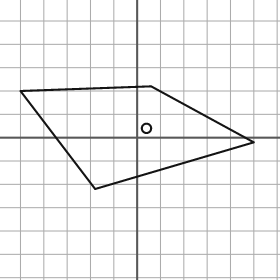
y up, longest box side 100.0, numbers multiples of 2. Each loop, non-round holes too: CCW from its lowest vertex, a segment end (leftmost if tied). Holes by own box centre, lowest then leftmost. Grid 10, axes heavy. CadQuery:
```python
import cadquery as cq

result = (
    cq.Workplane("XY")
    .moveTo(-18.0, -22.0)
    .lineTo(50.0, -2.0)
    .lineTo(6.0, 22.0)
    .lineTo(-50.0, 20.0)
    .close()
    .moveTo(4.0, 4.0)
    .circle(2.0)
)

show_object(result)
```